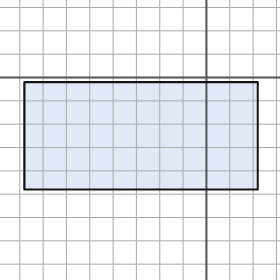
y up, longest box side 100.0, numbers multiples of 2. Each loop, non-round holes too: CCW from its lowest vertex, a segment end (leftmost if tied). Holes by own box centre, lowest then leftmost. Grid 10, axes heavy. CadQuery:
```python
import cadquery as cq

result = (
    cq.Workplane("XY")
    .moveTo(-78.0, -48.0)
    .lineTo(22.0, -48.0)
    .lineTo(22.0, -2.0)
    .lineTo(-78.0, -2.0)
    .close()
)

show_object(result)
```